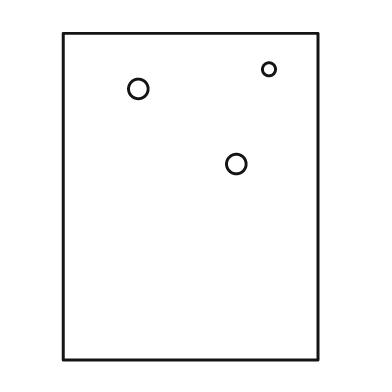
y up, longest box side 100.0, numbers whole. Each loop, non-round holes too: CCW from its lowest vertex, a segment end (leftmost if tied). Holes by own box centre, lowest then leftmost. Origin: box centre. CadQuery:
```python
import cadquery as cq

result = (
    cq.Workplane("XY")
    .moveTo(-39.0, -50.0)
    .lineTo(39.0, -50.0)
    .lineTo(39.0, 50.0)
    .lineTo(-39.0, 50.0)
    .close()
    .moveTo(14.0, 10.0)
    .circle(3.0)
    .moveTo(-16.0, 33.0)
    .circle(3.0)
    .moveTo(24.0, 39.0)
    .circle(2.0)
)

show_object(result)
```